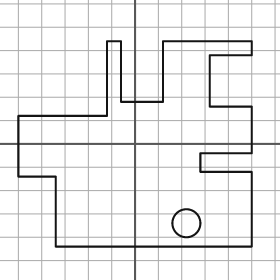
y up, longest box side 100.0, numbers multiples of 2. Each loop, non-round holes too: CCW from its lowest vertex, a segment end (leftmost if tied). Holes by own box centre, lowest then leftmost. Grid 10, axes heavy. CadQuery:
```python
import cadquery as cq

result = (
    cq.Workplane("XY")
    .moveTo(-34.0, -44.0)
    .lineTo(50.0, -44.0)
    .lineTo(50.0, -12.0)
    .lineTo(28.0, -12.0)
    .lineTo(28.0, -4.0)
    .lineTo(50.0, -4.0)
    .lineTo(50.0, 16.0)
    .lineTo(32.0, 16.0)
    .lineTo(32.0, 38.0)
    .lineTo(50.0, 38.0)
    .lineTo(50.0, 44.0)
    .lineTo(12.0, 44.0)
    .lineTo(12.0, 18.0)
    .lineTo(-6.0, 18.0)
    .lineTo(-6.0, 44.0)
    .lineTo(-12.0, 44.0)
    .lineTo(-12.0, 12.0)
    .lineTo(-50.0, 12.0)
    .lineTo(-50.0, -14.0)
    .lineTo(-34.0, -14.0)
    .close()
    .moveTo(22.0, -34.0)
    .circle(6.0)
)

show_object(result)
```